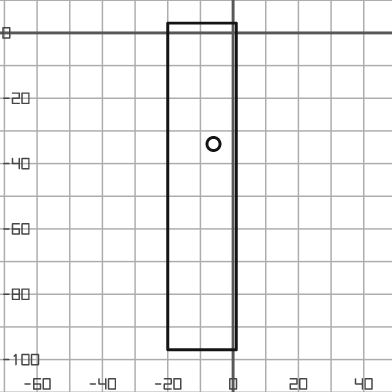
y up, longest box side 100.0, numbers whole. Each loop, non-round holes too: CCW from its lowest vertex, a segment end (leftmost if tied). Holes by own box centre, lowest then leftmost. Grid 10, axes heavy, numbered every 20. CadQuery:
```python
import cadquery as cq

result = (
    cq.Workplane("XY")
    .moveTo(-20.0, -97.0)
    .lineTo(1.0, -97.0)
    .lineTo(1.0, 3.0)
    .lineTo(-20.0, 3.0)
    .close()
    .moveTo(-6.0, -34.0)
    .circle(2.0)
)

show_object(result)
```